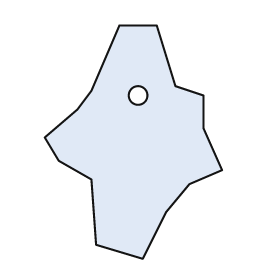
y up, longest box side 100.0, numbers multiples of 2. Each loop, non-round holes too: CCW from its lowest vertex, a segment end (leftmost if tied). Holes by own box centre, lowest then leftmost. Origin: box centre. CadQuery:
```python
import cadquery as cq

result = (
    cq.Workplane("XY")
    .moveTo(4.0, -50.0)
    .lineTo(14.0, -30.0)
    .lineTo(24.0, -18.0)
    .lineTo(38.0, -12.0)
    .lineTo(30.0, 6.0)
    .lineTo(30.0, 20.0)
    .lineTo(18.0, 24.0)
    .lineTo(10.0, 50.0)
    .lineTo(-6.0, 50.0)
    .lineTo(-18.0, 22.0)
    .lineTo(-24.0, 14.0)
    .lineTo(-38.0, 2.0)
    .lineTo(-32.0, -8.0)
    .lineTo(-18.0, -16.0)
    .lineTo(-16.0, -44.0)
    .close()
    .moveTo(2.0, 20.0)
    .circle(4.0)
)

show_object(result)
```